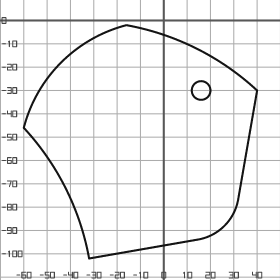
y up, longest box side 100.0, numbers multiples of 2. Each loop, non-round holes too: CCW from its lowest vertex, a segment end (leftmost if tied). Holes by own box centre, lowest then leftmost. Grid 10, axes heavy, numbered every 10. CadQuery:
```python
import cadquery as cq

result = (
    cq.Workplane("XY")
    .moveTo(-32.0, -102.0)
    .lineTo(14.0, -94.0)
    .threePointArc((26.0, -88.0), (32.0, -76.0))
    .lineTo(40.0, -30.0)
    .threePointArc((14.0, -12.0), (-16.0, -2.0))
    .threePointArc((-44.0, -18.0), (-60.0, -46.0))
    .threePointArc((-42.0, -72.0), (-32.0, -102.0))
    .close()
    .moveTo(16.0, -30.0)
    .circle(4.0)
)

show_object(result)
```